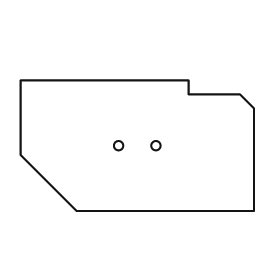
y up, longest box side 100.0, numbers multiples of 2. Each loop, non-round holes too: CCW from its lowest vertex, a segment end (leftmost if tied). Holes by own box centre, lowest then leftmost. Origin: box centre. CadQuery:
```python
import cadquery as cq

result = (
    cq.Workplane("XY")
    .moveTo(-26.0, -28.0)
    .lineTo(50.0, -28.0)
    .lineTo(50.0, 16.0)
    .lineTo(44.0, 22.0)
    .lineTo(22.0, 22.0)
    .lineTo(22.0, 28.0)
    .lineTo(-50.0, 28.0)
    .lineTo(-50.0, -4.0)
    .close()
    .moveTo(-8.0, 0.0)
    .circle(2.0)
    .moveTo(8.0, 0.0)
    .circle(2.0)
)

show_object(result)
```